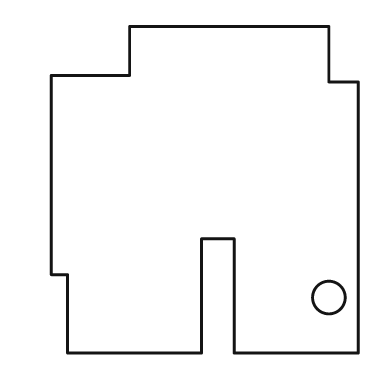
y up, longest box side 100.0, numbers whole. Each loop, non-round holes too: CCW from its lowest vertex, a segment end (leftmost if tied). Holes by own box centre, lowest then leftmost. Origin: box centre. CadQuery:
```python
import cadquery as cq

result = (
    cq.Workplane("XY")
    .moveTo(-42.0, -50.0)
    .lineTo(-1.0, -50.0)
    .lineTo(-1.0, -15.0)
    .lineTo(9.0, -15.0)
    .lineTo(9.0, -50.0)
    .lineTo(47.0, -50.0)
    .lineTo(47.0, 33.0)
    .lineTo(38.0, 33.0)
    .lineTo(38.0, 50.0)
    .lineTo(-23.0, 50.0)
    .lineTo(-23.0, 35.0)
    .lineTo(-47.0, 35.0)
    .lineTo(-47.0, -26.0)
    .lineTo(-42.0, -26.0)
    .close()
    .moveTo(38.0, -33.0)
    .circle(5.0)
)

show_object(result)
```